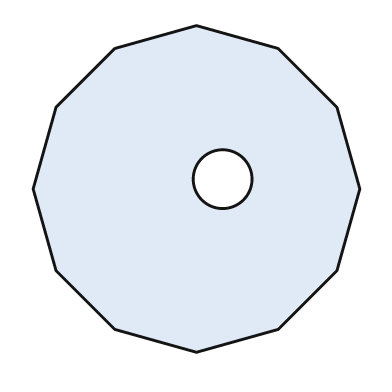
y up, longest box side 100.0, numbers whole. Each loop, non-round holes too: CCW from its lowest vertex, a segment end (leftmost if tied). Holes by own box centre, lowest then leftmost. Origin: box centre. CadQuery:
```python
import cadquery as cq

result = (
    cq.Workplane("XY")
    .moveTo(0.0, -50.0)
    .lineTo(25.0, -43.0)
    .lineTo(43.0, -25.0)
    .lineTo(50.0, 0.0)
    .lineTo(43.0, 25.0)
    .lineTo(25.0, 43.0)
    .lineTo(0.0, 50.0)
    .lineTo(-25.0, 43.0)
    .lineTo(-43.0, 25.0)
    .lineTo(-50.0, 0.0)
    .lineTo(-43.0, -25.0)
    .lineTo(-25.0, -43.0)
    .close()
    .moveTo(8.0, 3.0)
    .circle(9.0)
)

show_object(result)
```